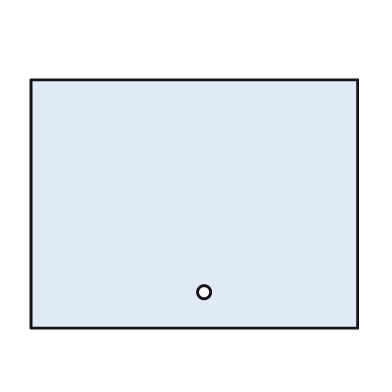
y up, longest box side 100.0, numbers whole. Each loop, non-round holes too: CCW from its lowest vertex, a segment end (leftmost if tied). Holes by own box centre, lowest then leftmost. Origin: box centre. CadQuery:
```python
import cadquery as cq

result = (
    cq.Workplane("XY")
    .moveTo(-50.0, -38.0)
    .lineTo(50.0, -38.0)
    .lineTo(50.0, 38.0)
    .lineTo(-50.0, 38.0)
    .close()
    .moveTo(3.0, -27.0)
    .circle(2.0)
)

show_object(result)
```